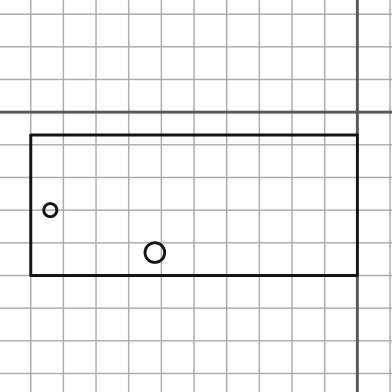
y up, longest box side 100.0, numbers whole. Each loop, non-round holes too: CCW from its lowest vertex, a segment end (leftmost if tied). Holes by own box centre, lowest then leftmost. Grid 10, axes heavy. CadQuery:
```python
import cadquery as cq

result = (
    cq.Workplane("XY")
    .moveTo(-100.0, -50.0)
    .lineTo(0.0, -50.0)
    .lineTo(0.0, -7.0)
    .lineTo(-100.0, -7.0)
    .close()
    .moveTo(-62.0, -43.0)
    .circle(3.0)
    .moveTo(-94.0, -30.0)
    .circle(2.0)
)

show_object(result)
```